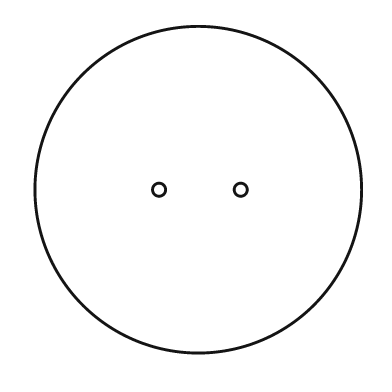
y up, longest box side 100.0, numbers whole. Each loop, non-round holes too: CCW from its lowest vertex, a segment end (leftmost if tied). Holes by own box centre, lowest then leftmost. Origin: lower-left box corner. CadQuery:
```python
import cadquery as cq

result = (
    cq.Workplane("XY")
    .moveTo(50.0, 50.0)
    .circle(50.0)
    .moveTo(38.0, 50.0)
    .circle(2.0)
    .moveTo(63.0, 50.0)
    .circle(2.0)
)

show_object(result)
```